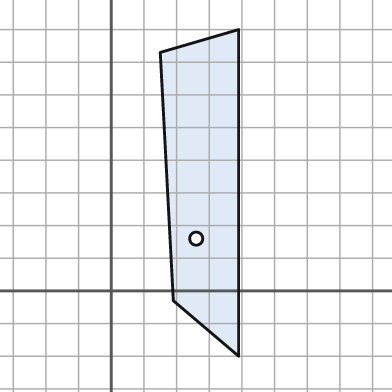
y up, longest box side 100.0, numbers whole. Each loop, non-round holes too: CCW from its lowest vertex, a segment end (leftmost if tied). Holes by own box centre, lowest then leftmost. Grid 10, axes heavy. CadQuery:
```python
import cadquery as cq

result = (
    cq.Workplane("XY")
    .moveTo(39.0, -20.0)
    .lineTo(39.0, 80.0)
    .lineTo(15.0, 73.0)
    .lineTo(19.0, -3.0)
    .close()
    .moveTo(26.0, 16.0)
    .circle(2.0)
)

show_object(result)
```